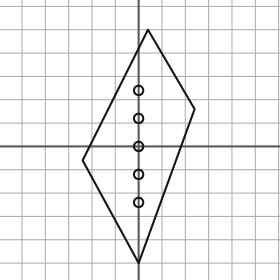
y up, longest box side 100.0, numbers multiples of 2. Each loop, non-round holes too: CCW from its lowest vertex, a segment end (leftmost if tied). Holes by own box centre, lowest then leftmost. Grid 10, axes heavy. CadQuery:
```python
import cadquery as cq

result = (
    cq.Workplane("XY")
    .moveTo(0.0, -50.0)
    .lineTo(24.0, 16.0)
    .lineTo(4.0, 50.0)
    .lineTo(-24.0, -6.0)
    .close()
    .moveTo(0.0, -24.0)
    .circle(2.0)
    .moveTo(0.0, -12.0)
    .circle(2.0)
    .moveTo(0.0, 0.0)
    .circle(2.0)
    .moveTo(0.0, 12.0)
    .circle(2.0)
    .moveTo(0.0, 24.0)
    .circle(2.0)
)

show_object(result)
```